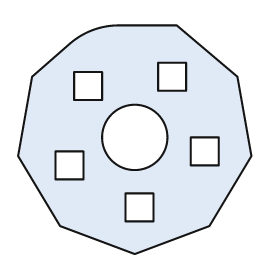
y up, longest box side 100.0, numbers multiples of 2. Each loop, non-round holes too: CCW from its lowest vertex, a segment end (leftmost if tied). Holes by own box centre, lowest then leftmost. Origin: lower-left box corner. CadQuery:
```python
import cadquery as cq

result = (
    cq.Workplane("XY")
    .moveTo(50.0, 0.0)
    .lineTo(82.0, 12.0)
    .lineTo(100.0, 42.0)
    .lineTo(94.0, 76.0)
    .lineTo(68.0, 98.0)
    .lineTo(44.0, 98.0)
    .threePointArc((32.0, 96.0), (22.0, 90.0))
    .lineTo(6.0, 76.0)
    .lineTo(0.0, 42.0)
    .lineTo(18.0, 12.0)
    .close()
    .moveTo(46.0, 14.0)
    .lineTo(58.0, 14.0)
    .lineTo(58.0, 26.0)
    .lineTo(46.0, 26.0)
    .close()
    .moveTo(16.0, 32.0)
    .lineTo(28.0, 32.0)
    .lineTo(28.0, 44.0)
    .lineTo(16.0, 44.0)
    .close()
    .moveTo(74.0, 38.0)
    .lineTo(86.0, 38.0)
    .lineTo(86.0, 50.0)
    .lineTo(74.0, 50.0)
    .close()
    .moveTo(50.0, 50.0)
    .circle(14.0)
    .moveTo(24.0, 66.0)
    .lineTo(36.0, 66.0)
    .lineTo(36.0, 78.0)
    .lineTo(24.0, 78.0)
    .close()
    .moveTo(60.0, 70.0)
    .lineTo(72.0, 70.0)
    .lineTo(72.0, 82.0)
    .lineTo(60.0, 82.0)
    .close()
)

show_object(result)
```